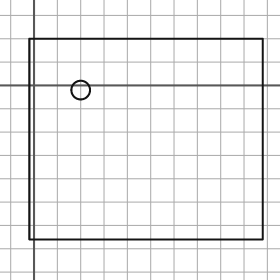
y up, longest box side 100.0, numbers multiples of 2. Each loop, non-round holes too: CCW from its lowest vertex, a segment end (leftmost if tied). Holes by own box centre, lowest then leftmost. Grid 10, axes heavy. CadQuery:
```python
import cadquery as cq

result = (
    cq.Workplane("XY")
    .moveTo(-2.0, -66.0)
    .lineTo(98.0, -66.0)
    .lineTo(98.0, 20.0)
    .lineTo(-2.0, 20.0)
    .close()
    .moveTo(20.0, -2.0)
    .circle(4.0)
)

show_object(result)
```